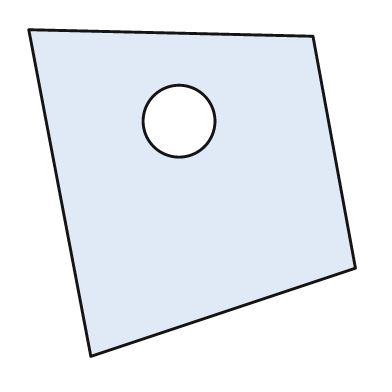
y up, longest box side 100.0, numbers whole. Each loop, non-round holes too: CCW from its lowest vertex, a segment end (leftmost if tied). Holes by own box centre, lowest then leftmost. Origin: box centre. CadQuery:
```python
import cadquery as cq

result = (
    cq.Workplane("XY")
    .moveTo(-31.0, -50.0)
    .lineTo(50.0, -23.0)
    .lineTo(37.0, 48.0)
    .lineTo(-50.0, 50.0)
    .close()
    .moveTo(-4.0, 22.0)
    .circle(11.0)
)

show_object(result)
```